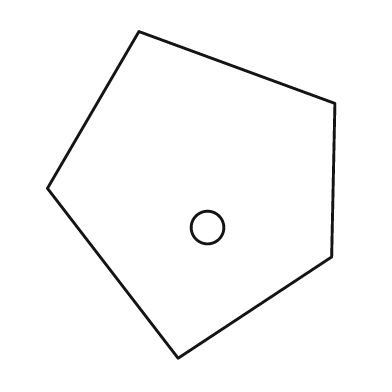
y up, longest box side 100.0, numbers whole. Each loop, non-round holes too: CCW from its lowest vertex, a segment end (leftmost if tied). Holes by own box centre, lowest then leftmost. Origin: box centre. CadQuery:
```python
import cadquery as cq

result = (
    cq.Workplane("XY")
    .moveTo(-4.0, -50.0)
    .lineTo(43.0, -19.0)
    .lineTo(44.0, 28.0)
    .lineTo(-16.0, 50.0)
    .lineTo(-44.0, 2.0)
    .close()
    .moveTo(5.0, -10.0)
    .circle(5.0)
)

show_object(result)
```